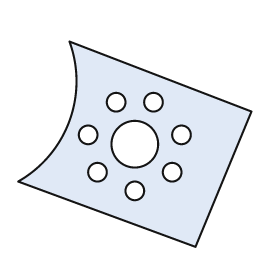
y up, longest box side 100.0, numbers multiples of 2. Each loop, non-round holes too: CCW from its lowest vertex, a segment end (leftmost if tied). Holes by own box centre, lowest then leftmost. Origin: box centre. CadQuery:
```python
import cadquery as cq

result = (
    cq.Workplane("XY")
    .moveTo(26.0, -44.0)
    .lineTo(50.0, 14.0)
    .lineTo(-28.0, 44.0)
    .threePointArc((-28.0, 10.0), (-50.0, -16.0))
    .close()
    .moveTo(0.0, -20.0)
    .circle(4.0)
    .moveTo(-16.0, -12.0)
    .circle(4.0)
    .moveTo(16.0, -12.0)
    .circle(4.0)
    .moveTo(0.0, 0.0)
    .circle(10.0)
    .moveTo(-20.0, 4.0)
    .circle(4.0)
    .moveTo(20.0, 4.0)
    .circle(4.0)
    .moveTo(-8.0, 18.0)
    .circle(4.0)
    .moveTo(8.0, 18.0)
    .circle(4.0)
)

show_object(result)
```